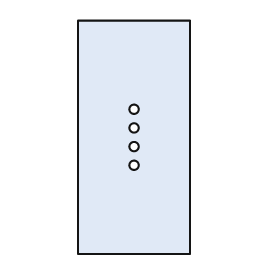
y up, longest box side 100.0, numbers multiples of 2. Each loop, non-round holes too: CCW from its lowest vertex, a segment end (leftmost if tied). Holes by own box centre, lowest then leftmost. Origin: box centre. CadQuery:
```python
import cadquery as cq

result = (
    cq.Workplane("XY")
    .moveTo(-24.0, -50.0)
    .lineTo(24.0, -50.0)
    .lineTo(24.0, 50.0)
    .lineTo(-24.0, 50.0)
    .close()
    .moveTo(0.0, -12.0)
    .circle(2.0)
    .moveTo(0.0, -4.0)
    .circle(2.0)
    .moveTo(0.0, 4.0)
    .circle(2.0)
    .moveTo(0.0, 12.0)
    .circle(2.0)
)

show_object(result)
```